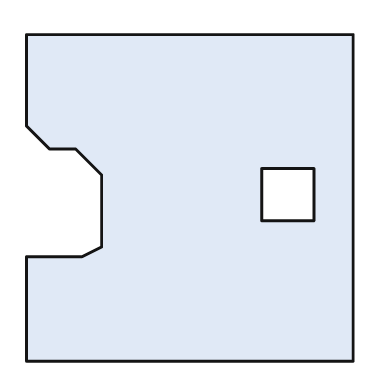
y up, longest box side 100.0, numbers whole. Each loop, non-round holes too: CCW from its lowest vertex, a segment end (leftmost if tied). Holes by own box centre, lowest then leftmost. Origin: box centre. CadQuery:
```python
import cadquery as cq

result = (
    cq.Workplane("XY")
    .moveTo(-50.0, -50.0)
    .lineTo(50.0, -50.0)
    .lineTo(50.0, 50.0)
    .lineTo(-50.0, 50.0)
    .lineTo(-50.0, 22.0)
    .lineTo(-43.0, 15.0)
    .lineTo(-35.0, 15.0)
    .lineTo(-27.0, 7.0)
    .lineTo(-27.0, -15.0)
    .lineTo(-33.0, -18.0)
    .lineTo(-50.0, -18.0)
    .close()
    .moveTo(22.0, -7.0)
    .lineTo(38.0, -7.0)
    .lineTo(38.0, 9.0)
    .lineTo(22.0, 9.0)
    .close()
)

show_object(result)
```